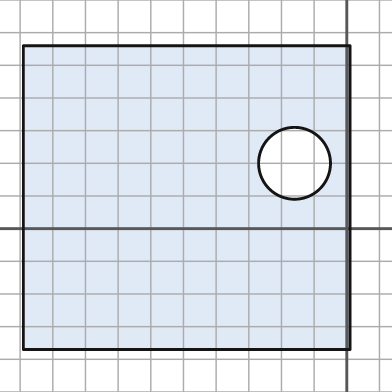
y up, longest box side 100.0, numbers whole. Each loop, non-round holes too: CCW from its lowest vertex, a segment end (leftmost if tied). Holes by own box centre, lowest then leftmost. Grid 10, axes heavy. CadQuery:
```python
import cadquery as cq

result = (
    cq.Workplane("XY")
    .moveTo(-99.0, -37.0)
    .lineTo(1.0, -37.0)
    .lineTo(1.0, 56.0)
    .lineTo(-99.0, 56.0)
    .close()
    .moveTo(-16.0, 20.0)
    .circle(11.0)
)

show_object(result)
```